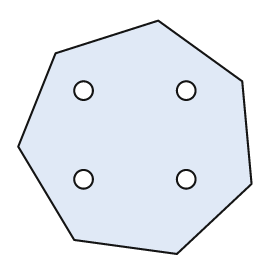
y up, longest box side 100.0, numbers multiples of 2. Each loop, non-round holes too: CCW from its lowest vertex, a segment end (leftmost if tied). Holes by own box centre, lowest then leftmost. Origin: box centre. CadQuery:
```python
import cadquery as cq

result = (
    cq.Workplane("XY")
    .moveTo(18.0, -50.0)
    .lineTo(50.0, -20.0)
    .lineTo(46.0, 24.0)
    .lineTo(10.0, 50.0)
    .lineTo(-34.0, 36.0)
    .lineTo(-50.0, -4.0)
    .lineTo(-26.0, -44.0)
    .close()
    .moveTo(-22.0, -18.0)
    .circle(4.0)
    .moveTo(22.0, -18.0)
    .circle(4.0)
    .moveTo(-22.0, 20.0)
    .circle(4.0)
    .moveTo(22.0, 20.0)
    .circle(4.0)
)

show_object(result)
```